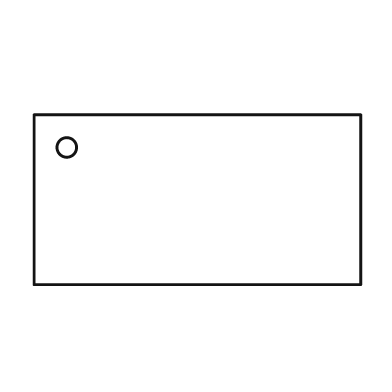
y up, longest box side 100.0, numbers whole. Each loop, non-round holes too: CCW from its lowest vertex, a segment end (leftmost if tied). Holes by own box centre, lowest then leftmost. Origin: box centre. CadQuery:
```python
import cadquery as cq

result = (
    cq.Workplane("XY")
    .moveTo(-50.0, -26.0)
    .lineTo(50.0, -26.0)
    .lineTo(50.0, 26.0)
    .lineTo(-50.0, 26.0)
    .close()
    .moveTo(-40.0, 16.0)
    .circle(3.0)
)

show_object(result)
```